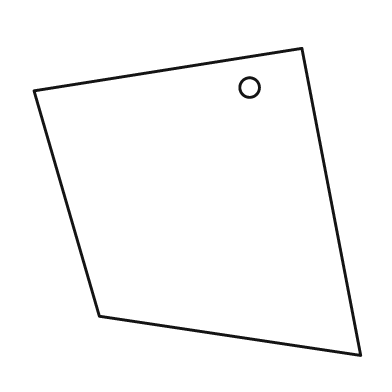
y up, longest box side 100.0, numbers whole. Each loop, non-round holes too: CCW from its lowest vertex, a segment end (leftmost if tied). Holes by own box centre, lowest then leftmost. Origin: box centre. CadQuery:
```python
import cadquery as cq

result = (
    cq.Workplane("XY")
    .moveTo(50.0, -47.0)
    .lineTo(32.0, 47.0)
    .lineTo(-50.0, 34.0)
    .lineTo(-30.0, -35.0)
    .close()
    .moveTo(16.0, 35.0)
    .circle(3.0)
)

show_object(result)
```